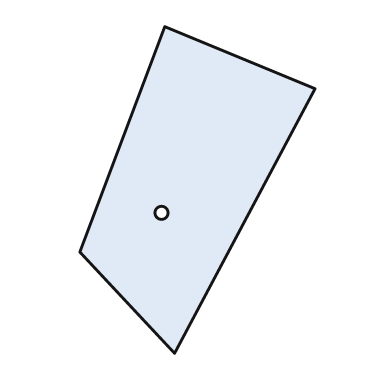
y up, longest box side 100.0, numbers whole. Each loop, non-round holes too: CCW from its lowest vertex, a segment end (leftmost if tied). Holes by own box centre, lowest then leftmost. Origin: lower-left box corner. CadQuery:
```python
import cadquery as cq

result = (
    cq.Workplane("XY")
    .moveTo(29.0, 0.0)
    .lineTo(72.0, 81.0)
    .lineTo(26.0, 100.0)
    .lineTo(0.0, 31.0)
    .close()
    .moveTo(25.0, 43.0)
    .circle(2.0)
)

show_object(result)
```